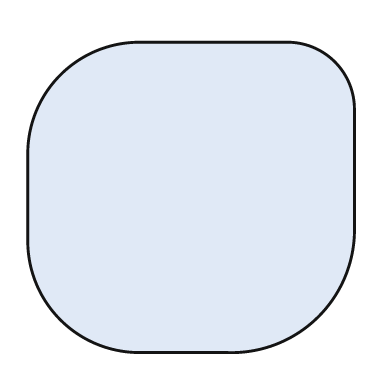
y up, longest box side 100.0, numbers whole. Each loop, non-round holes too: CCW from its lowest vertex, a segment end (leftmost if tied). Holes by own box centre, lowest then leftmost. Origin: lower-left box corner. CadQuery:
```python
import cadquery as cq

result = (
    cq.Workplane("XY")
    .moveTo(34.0, 0.0)
    .lineTo(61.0, 0.0)
    .threePointArc((89.0, 11.0), (100.0, 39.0))
    .lineTo(100.0, 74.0)
    .threePointArc((94.0, 89.0), (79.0, 95.0))
    .lineTo(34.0, 95.0)
    .threePointArc((10.0, 85.0), (0.0, 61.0))
    .lineTo(0.0, 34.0)
    .threePointArc((10.0, 10.0), (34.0, 0.0))
    .close()
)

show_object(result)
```